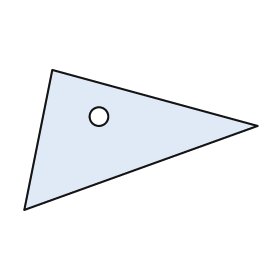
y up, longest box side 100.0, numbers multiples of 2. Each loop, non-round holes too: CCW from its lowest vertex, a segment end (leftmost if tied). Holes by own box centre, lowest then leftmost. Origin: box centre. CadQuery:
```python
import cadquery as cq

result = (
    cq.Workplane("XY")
    .moveTo(-50.0, -30.0)
    .lineTo(50.0, 6.0)
    .lineTo(-38.0, 30.0)
    .close()
    .moveTo(-18.0, 10.0)
    .circle(4.0)
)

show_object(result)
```